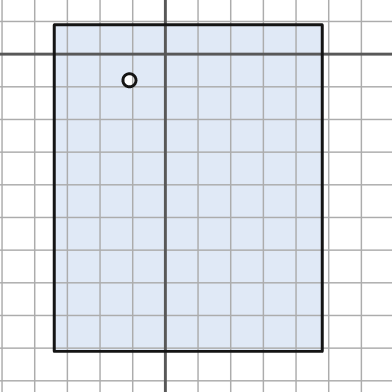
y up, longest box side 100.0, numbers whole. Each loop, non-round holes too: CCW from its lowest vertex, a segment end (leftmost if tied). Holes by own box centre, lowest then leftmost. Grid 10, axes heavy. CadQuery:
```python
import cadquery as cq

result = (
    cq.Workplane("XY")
    .moveTo(-34.0, -91.0)
    .lineTo(48.0, -91.0)
    .lineTo(48.0, 9.0)
    .lineTo(-34.0, 9.0)
    .close()
    .moveTo(-11.0, -8.0)
    .circle(2.0)
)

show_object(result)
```